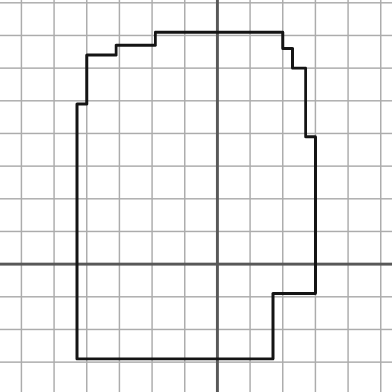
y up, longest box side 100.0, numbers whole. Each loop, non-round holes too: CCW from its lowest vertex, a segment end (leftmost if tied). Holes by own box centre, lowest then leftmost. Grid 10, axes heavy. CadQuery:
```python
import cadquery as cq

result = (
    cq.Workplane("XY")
    .moveTo(-43.0, -29.0)
    .lineTo(17.0, -29.0)
    .lineTo(17.0, -9.0)
    .lineTo(30.0, -9.0)
    .lineTo(30.0, 39.0)
    .lineTo(27.0, 39.0)
    .lineTo(27.0, 60.0)
    .lineTo(23.0, 60.0)
    .lineTo(23.0, 66.0)
    .lineTo(20.0, 66.0)
    .lineTo(20.0, 71.0)
    .lineTo(-19.0, 71.0)
    .lineTo(-19.0, 67.0)
    .lineTo(-31.0, 67.0)
    .lineTo(-31.0, 64.0)
    .lineTo(-40.0, 64.0)
    .lineTo(-40.0, 49.0)
    .lineTo(-43.0, 49.0)
    .close()
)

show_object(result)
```